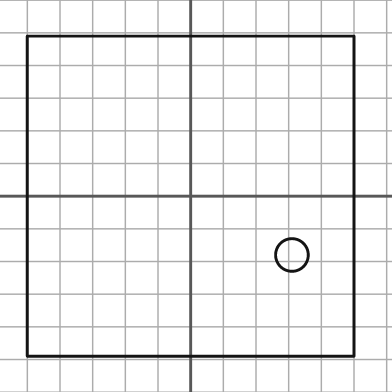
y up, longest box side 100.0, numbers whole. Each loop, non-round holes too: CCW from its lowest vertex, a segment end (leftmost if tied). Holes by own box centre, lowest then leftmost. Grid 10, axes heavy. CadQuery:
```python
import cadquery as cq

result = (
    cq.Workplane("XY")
    .moveTo(-50.0, -49.0)
    .lineTo(50.0, -49.0)
    .lineTo(50.0, 49.0)
    .lineTo(-50.0, 49.0)
    .close()
    .moveTo(31.0, -18.0)
    .circle(5.0)
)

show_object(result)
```